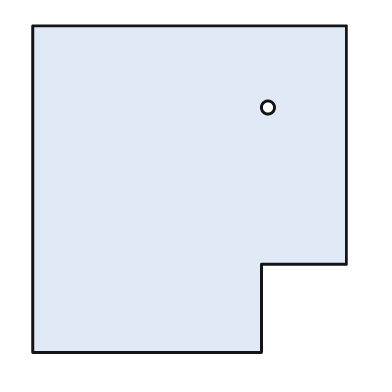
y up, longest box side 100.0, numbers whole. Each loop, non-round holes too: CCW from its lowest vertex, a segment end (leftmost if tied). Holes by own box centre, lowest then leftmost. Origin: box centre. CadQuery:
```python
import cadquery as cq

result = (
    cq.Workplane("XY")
    .moveTo(-48.0, -50.0)
    .lineTo(22.0, -50.0)
    .lineTo(22.0, -23.0)
    .lineTo(48.0, -23.0)
    .lineTo(48.0, 50.0)
    .lineTo(-48.0, 50.0)
    .close()
    .moveTo(24.0, 25.0)
    .circle(2.0)
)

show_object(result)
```